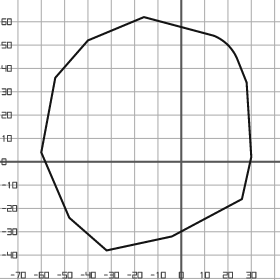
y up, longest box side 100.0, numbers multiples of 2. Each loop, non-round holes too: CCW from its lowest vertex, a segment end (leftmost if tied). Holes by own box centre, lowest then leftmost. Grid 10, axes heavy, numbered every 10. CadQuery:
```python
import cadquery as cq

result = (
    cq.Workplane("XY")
    .moveTo(-32.0, -38.0)
    .lineTo(-4.0, -32.0)
    .lineTo(26.0, -16.0)
    .lineTo(30.0, 2.0)
    .lineTo(28.0, 34.0)
    .lineTo(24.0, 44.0)
    .threePointArc((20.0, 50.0), (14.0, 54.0))
    .lineTo(-16.0, 62.0)
    .lineTo(-40.0, 52.0)
    .lineTo(-54.0, 36.0)
    .lineTo(-60.0, 4.0)
    .lineTo(-48.0, -24.0)
    .close()
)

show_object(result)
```